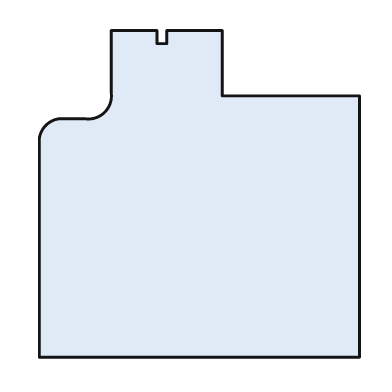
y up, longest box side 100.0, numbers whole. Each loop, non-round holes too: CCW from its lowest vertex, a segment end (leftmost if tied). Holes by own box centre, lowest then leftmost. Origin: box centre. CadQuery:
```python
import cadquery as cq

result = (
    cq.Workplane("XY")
    .moveTo(-49.0, -50.0)
    .lineTo(49.0, -50.0)
    .lineTo(49.0, 30.0)
    .lineTo(7.0, 30.0)
    .lineTo(7.0, 50.0)
    .lineTo(-10.0, 50.0)
    .lineTo(-10.0, 46.0)
    .lineTo(-13.0, 46.0)
    .lineTo(-13.0, 50.0)
    .lineTo(-27.0, 50.0)
    .lineTo(-27.0, 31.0)
    .threePointArc((-29.0, 25.0), (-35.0, 23.0))
    .lineTo(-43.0, 23.0)
    .threePointArc((-47.0, 21.0), (-49.0, 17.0))
    .close()
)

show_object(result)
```